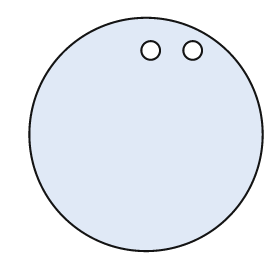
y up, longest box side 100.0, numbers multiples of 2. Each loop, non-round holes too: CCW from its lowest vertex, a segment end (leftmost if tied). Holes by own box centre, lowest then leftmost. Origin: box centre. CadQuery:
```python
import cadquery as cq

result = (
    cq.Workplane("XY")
    .moveTo(0.0, 0.0)
    .circle(50.0)
    .moveTo(2.0, 36.0)
    .circle(4.0)
    .moveTo(20.0, 36.0)
    .circle(4.0)
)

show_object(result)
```